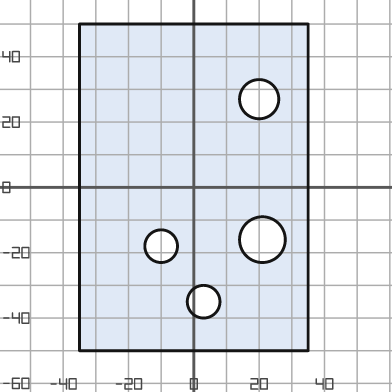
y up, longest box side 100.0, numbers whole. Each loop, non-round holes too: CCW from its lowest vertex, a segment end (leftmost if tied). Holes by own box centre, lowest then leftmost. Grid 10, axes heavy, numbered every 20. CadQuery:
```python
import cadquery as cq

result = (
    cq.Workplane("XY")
    .moveTo(-35.0, -50.0)
    .lineTo(35.0, -50.0)
    .lineTo(35.0, 50.0)
    .lineTo(-35.0, 50.0)
    .close()
    .moveTo(3.0, -35.0)
    .circle(5.0)
    .moveTo(-10.0, -18.0)
    .circle(5.0)
    .moveTo(21.0, -16.0)
    .circle(7.0)
    .moveTo(20.0, 27.0)
    .circle(6.0)
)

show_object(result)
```